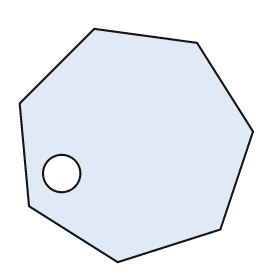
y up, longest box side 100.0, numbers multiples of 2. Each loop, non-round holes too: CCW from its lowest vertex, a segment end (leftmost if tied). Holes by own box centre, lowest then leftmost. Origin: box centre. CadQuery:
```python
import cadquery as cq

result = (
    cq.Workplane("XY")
    .moveTo(-8.0, -50.0)
    .lineTo(36.0, -36.0)
    .lineTo(50.0, 6.0)
    .lineTo(26.0, 44.0)
    .lineTo(-18.0, 50.0)
    .lineTo(-50.0, 18.0)
    .lineTo(-46.0, -26.0)
    .close()
    .moveTo(-32.0, -12.0)
    .circle(8.0)
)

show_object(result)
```